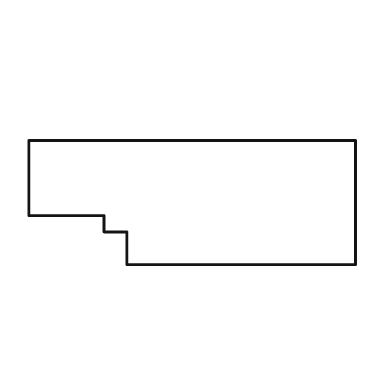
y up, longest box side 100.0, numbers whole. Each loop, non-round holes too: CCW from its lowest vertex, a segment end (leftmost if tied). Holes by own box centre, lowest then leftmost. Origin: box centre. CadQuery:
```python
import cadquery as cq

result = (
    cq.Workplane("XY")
    .moveTo(-20.0, -19.0)
    .lineTo(50.0, -19.0)
    .lineTo(50.0, 19.0)
    .lineTo(-50.0, 19.0)
    .lineTo(-50.0, -4.0)
    .lineTo(-27.0, -4.0)
    .lineTo(-27.0, -9.0)
    .lineTo(-20.0, -9.0)
    .close()
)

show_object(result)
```